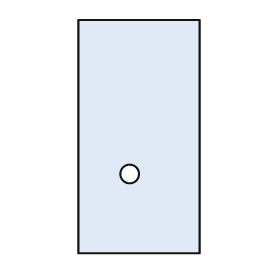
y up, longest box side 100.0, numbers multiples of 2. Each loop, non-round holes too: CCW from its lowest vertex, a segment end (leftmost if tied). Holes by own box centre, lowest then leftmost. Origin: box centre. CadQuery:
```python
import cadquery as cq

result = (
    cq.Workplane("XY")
    .moveTo(-26.0, -50.0)
    .lineTo(26.0, -50.0)
    .lineTo(26.0, 50.0)
    .lineTo(-26.0, 50.0)
    .close()
    .moveTo(-4.0, -16.0)
    .circle(4.0)
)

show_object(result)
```